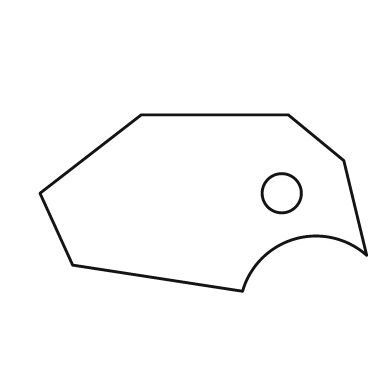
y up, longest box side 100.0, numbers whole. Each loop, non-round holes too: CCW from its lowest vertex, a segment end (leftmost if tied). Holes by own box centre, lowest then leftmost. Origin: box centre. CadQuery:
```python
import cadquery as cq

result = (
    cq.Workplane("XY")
    .moveTo(12.0, -27.0)
    .threePointArc((28.0, -11.0), (50.0, -16.0))
    .lineTo(43.0, 13.0)
    .lineTo(26.0, 27.0)
    .lineTo(-19.0, 27.0)
    .lineTo(-50.0, 3.0)
    .lineTo(-40.0, -19.0)
    .close()
    .moveTo(24.0, 3.0)
    .circle(6.0)
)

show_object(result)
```